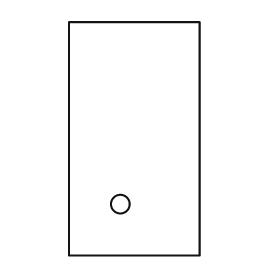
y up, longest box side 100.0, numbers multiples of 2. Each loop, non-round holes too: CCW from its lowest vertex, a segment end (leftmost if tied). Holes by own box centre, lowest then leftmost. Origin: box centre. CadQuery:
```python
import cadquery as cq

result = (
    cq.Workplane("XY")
    .moveTo(-28.0, -50.0)
    .lineTo(28.0, -50.0)
    .lineTo(28.0, 50.0)
    .lineTo(-28.0, 50.0)
    .close()
    .moveTo(-6.0, -28.0)
    .circle(4.0)
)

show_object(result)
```